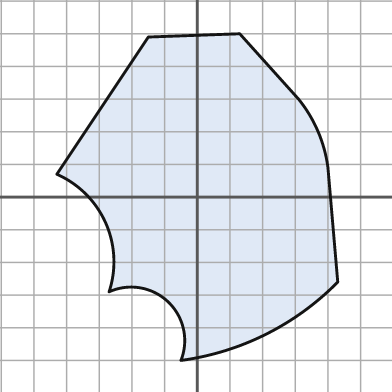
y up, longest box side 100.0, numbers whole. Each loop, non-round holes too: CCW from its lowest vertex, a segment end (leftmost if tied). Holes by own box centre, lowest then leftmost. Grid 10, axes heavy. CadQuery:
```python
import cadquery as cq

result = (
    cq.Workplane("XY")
    .moveTo(-5.0, -50.0)
    .threePointArc((21.0, -42.0), (43.0, -26.0))
    .lineTo(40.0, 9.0)
    .threePointArc((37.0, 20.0), (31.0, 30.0))
    .lineTo(13.0, 50.0)
    .lineTo(-15.0, 49.0)
    .lineTo(-43.0, 7.0)
    .threePointArc((-28.0, -8.0), (-27.0, -29.0))
    .threePointArc((-9.0, -32.0), (-5.0, -50.0))
    .close()
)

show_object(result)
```